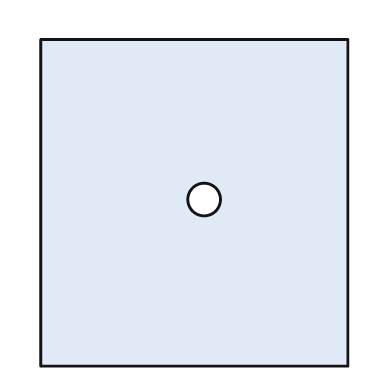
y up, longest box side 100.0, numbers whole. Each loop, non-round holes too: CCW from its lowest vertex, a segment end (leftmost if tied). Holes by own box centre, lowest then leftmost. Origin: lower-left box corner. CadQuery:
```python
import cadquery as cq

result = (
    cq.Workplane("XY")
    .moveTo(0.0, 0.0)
    .lineTo(94.0, 0.0)
    .lineTo(94.0, 100.0)
    .lineTo(0.0, 100.0)
    .close()
    .moveTo(50.0, 51.0)
    .circle(5.0)
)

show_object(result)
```